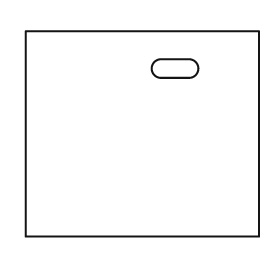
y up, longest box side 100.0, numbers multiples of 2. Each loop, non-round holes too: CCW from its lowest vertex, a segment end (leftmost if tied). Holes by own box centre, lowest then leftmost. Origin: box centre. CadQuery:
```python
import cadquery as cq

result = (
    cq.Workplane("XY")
    .moveTo(-50.0, -44.0)
    .lineTo(50.0, -44.0)
    .lineTo(50.0, 44.0)
    .lineTo(-50.0, 44.0)
    .close()
    .moveTo(8.0, 24.0)
    .lineTo(20.0, 24.0)
    .threePointArc((24.0, 28.0), (20.0, 32.0))
    .lineTo(8.0, 32.0)
    .threePointArc((4.0, 28.0), (8.0, 24.0))
    .close()
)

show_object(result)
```